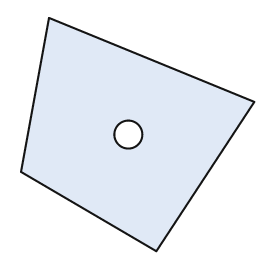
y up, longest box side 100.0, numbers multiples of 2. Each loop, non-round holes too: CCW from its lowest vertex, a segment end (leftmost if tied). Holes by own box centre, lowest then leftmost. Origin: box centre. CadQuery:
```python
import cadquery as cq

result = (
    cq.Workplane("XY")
    .moveTo(8.0, -50.0)
    .lineTo(50.0, 14.0)
    .lineTo(-38.0, 50.0)
    .lineTo(-50.0, -16.0)
    .close()
    .moveTo(-4.0, 0.0)
    .circle(6.0)
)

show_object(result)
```